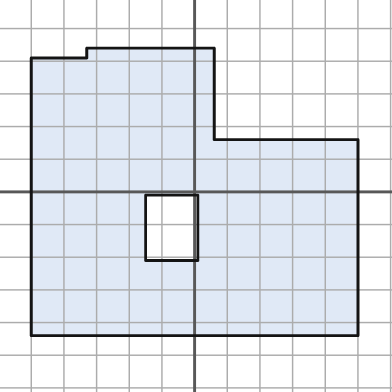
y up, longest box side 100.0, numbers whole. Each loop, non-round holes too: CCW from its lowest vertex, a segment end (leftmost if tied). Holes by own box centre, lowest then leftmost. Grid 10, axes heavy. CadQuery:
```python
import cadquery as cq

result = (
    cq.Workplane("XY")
    .moveTo(-50.0, -44.0)
    .lineTo(50.0, -44.0)
    .lineTo(50.0, 16.0)
    .lineTo(6.0, 16.0)
    .lineTo(6.0, 44.0)
    .lineTo(-33.0, 44.0)
    .lineTo(-33.0, 41.0)
    .lineTo(-50.0, 41.0)
    .close()
    .moveTo(-15.0, -21.0)
    .lineTo(1.0, -21.0)
    .lineTo(1.0, -1.0)
    .lineTo(-15.0, -1.0)
    .close()
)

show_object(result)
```